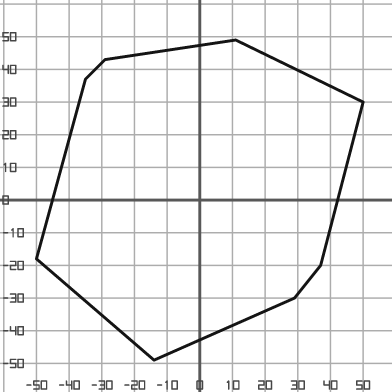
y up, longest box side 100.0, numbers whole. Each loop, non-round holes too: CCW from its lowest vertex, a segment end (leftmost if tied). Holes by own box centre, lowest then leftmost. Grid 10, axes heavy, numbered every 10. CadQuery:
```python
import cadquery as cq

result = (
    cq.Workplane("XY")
    .moveTo(-14.0, -49.0)
    .lineTo(29.0, -30.0)
    .lineTo(37.0, -20.0)
    .lineTo(50.0, 30.0)
    .lineTo(11.0, 49.0)
    .lineTo(-29.0, 43.0)
    .lineTo(-35.0, 37.0)
    .lineTo(-50.0, -18.0)
    .close()
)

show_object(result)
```